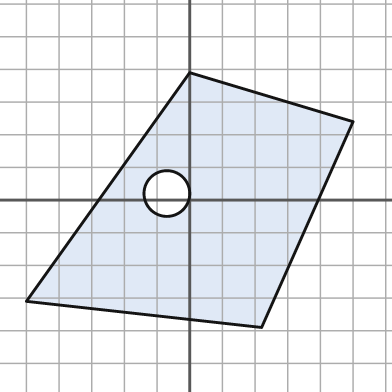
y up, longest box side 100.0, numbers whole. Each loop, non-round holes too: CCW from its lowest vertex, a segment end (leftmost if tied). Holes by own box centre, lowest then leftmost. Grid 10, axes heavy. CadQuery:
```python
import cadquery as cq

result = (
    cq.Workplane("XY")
    .moveTo(22.0, -39.0)
    .lineTo(50.0, 24.0)
    .lineTo(0.0, 39.0)
    .lineTo(-50.0, -31.0)
    .close()
    .moveTo(-7.0, 2.0)
    .circle(7.0)
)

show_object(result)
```